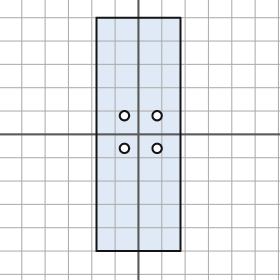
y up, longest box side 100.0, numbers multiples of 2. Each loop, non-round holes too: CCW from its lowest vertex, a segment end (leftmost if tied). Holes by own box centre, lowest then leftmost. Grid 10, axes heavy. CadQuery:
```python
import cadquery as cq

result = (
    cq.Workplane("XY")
    .moveTo(-18.0, -50.0)
    .lineTo(18.0, -50.0)
    .lineTo(18.0, 50.0)
    .lineTo(-18.0, 50.0)
    .close()
    .moveTo(-6.0, -6.0)
    .circle(2.0)
    .moveTo(8.0, -6.0)
    .circle(2.0)
    .moveTo(-6.0, 8.0)
    .circle(2.0)
    .moveTo(8.0, 8.0)
    .circle(2.0)
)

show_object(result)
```